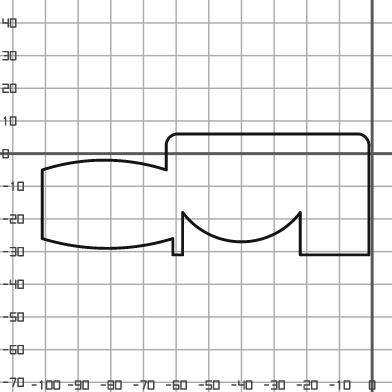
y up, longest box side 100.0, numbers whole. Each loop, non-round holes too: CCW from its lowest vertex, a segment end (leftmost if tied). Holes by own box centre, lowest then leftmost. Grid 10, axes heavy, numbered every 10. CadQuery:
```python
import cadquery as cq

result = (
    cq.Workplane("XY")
    .moveTo(-61.0, -31.0)
    .lineTo(-58.0, -31.0)
    .lineTo(-58.0, -18.0)
    .threePointArc((-40.0, -27.0), (-22.0, -18.0))
    .lineTo(-22.0, -31.0)
    .lineTo(-1.0, -31.0)
    .lineTo(-1.0, 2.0)
    .threePointArc((-2.0, 5.0), (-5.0, 6.0))
    .lineTo(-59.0, 6.0)
    .threePointArc((-62.0, 5.0), (-63.0, 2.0))
    .lineTo(-63.0, -5.0)
    .threePointArc((-82.0, -2.0), (-101.0, -5.0))
    .lineTo(-101.0, -26.0)
    .threePointArc((-81.0, -29.0), (-61.0, -26.0))
    .close()
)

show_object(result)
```